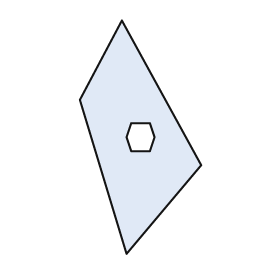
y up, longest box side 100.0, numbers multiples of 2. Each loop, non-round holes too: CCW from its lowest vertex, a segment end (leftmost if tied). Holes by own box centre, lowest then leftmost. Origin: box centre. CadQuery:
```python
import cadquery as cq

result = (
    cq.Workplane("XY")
    .moveTo(-6.0, -50.0)
    .lineTo(26.0, -12.0)
    .lineTo(-8.0, 50.0)
    .lineTo(-26.0, 16.0)
    .close()
    .moveTo(-4.0, -6.0)
    .lineTo(4.0, -6.0)
    .lineTo(6.0, 0.0)
    .lineTo(4.0, 6.0)
    .lineTo(-4.0, 6.0)
    .lineTo(-6.0, 0.0)
    .close()
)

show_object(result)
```